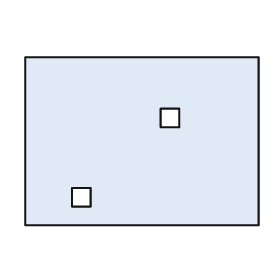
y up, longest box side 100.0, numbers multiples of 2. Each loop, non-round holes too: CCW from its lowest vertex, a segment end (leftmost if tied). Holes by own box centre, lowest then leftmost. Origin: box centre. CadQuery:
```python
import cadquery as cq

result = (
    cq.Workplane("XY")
    .moveTo(-50.0, -36.0)
    .lineTo(50.0, -36.0)
    .lineTo(50.0, 36.0)
    .lineTo(-50.0, 36.0)
    .close()
    .moveTo(-30.0, -28.0)
    .lineTo(-22.0, -28.0)
    .lineTo(-22.0, -20.0)
    .lineTo(-30.0, -20.0)
    .close()
    .moveTo(8.0, 6.0)
    .lineTo(16.0, 6.0)
    .lineTo(16.0, 14.0)
    .lineTo(8.0, 14.0)
    .close()
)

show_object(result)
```